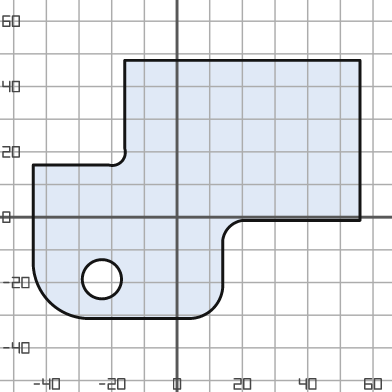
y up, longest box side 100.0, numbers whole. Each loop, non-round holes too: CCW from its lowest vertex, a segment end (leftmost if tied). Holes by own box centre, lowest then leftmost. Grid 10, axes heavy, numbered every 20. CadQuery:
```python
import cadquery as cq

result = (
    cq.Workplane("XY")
    .moveTo(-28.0, -31.0)
    .lineTo(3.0, -31.0)
    .threePointArc((11.0, -28.0), (14.0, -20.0))
    .lineTo(14.0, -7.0)
    .threePointArc((16.0, -3.0), (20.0, -1.0))
    .lineTo(56.0, -1.0)
    .lineTo(56.0, 48.0)
    .lineTo(-16.0, 48.0)
    .lineTo(-16.0, 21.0)
    .threePointArc((-17.0, 17.0), (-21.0, 16.0))
    .lineTo(-44.0, 16.0)
    .lineTo(-44.0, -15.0)
    .threePointArc((-39.0, -26.0), (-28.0, -31.0))
    .close()
    .moveTo(-23.0, -19.0)
    .circle(6.0)
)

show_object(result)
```